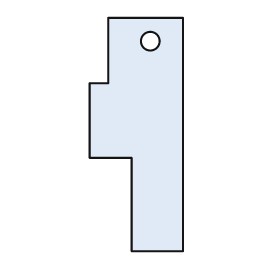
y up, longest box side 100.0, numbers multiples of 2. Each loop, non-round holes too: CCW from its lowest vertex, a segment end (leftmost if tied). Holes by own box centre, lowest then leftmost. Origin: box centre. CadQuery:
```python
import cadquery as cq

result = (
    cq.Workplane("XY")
    .moveTo(-2.0, -50.0)
    .lineTo(20.0, -50.0)
    .lineTo(20.0, 50.0)
    .lineTo(-12.0, 50.0)
    .lineTo(-12.0, 22.0)
    .lineTo(-20.0, 22.0)
    .lineTo(-20.0, -10.0)
    .lineTo(-2.0, -10.0)
    .close()
    .moveTo(6.0, 40.0)
    .circle(4.0)
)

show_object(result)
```